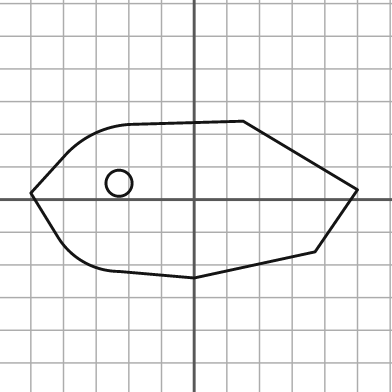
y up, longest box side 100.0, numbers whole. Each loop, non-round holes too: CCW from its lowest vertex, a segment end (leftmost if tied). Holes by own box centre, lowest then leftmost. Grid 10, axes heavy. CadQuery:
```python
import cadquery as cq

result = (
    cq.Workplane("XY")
    .moveTo(0.0, -24.0)
    .lineTo(37.0, -16.0)
    .lineTo(50.0, 3.0)
    .lineTo(15.0, 24.0)
    .lineTo(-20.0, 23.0)
    .threePointArc((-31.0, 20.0), (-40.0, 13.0))
    .lineTo(-50.0, 2.0)
    .lineTo(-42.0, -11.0)
    .threePointArc((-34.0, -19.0), (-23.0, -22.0))
    .close()
    .moveTo(-23.0, 5.0)
    .circle(4.0)
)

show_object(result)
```